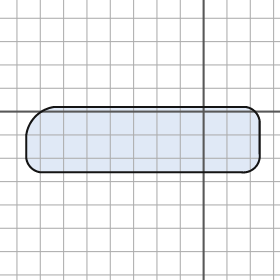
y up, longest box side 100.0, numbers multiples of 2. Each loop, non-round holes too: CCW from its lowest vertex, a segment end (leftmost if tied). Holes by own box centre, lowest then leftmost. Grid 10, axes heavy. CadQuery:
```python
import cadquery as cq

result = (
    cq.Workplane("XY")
    .moveTo(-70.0, -26.0)
    .lineTo(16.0, -26.0)
    .threePointArc((22.0, -24.0), (24.0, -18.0))
    .lineTo(24.0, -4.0)
    .threePointArc((22.0, 0.0), (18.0, 2.0))
    .lineTo(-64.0, 2.0)
    .threePointArc((-72.0, -2.0), (-76.0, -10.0))
    .lineTo(-76.0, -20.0)
    .threePointArc((-74.0, -24.0), (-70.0, -26.0))
    .close()
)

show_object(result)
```